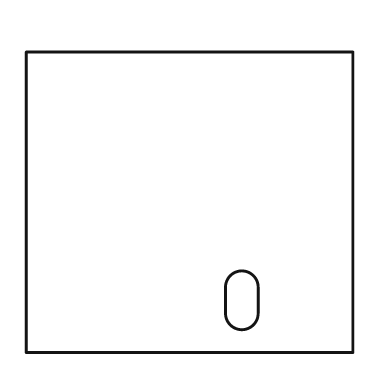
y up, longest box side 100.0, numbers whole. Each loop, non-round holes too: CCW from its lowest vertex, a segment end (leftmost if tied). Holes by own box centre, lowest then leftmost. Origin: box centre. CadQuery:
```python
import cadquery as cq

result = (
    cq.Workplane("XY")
    .moveTo(-50.0, -46.0)
    .lineTo(50.0, -46.0)
    .lineTo(50.0, 46.0)
    .lineTo(-50.0, 46.0)
    .close()
    .moveTo(11.0, -34.0)
    .threePointArc((16.0, -39.0), (21.0, -34.0))
    .lineTo(21.0, -26.0)
    .threePointArc((16.0, -21.0), (11.0, -26.0))
    .close()
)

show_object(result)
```